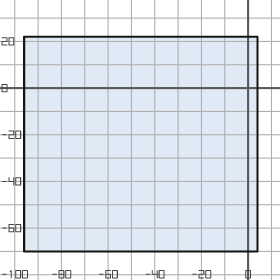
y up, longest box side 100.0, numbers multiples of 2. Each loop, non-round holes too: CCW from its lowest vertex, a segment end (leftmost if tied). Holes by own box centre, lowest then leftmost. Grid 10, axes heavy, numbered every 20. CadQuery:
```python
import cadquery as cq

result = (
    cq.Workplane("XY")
    .moveTo(-96.0, -70.0)
    .lineTo(4.0, -70.0)
    .lineTo(4.0, 22.0)
    .lineTo(-96.0, 22.0)
    .close()
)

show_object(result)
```